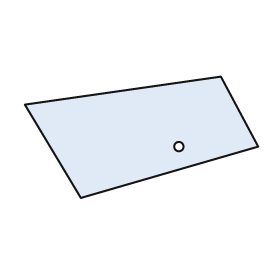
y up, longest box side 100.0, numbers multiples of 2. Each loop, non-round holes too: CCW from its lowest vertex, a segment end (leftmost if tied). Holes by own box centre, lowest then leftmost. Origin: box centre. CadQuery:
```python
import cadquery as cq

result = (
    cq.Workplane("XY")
    .moveTo(-26.0, -26.0)
    .lineTo(50.0, -4.0)
    .lineTo(34.0, 26.0)
    .lineTo(-50.0, 14.0)
    .close()
    .moveTo(16.0, -4.0)
    .circle(2.0)
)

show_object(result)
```